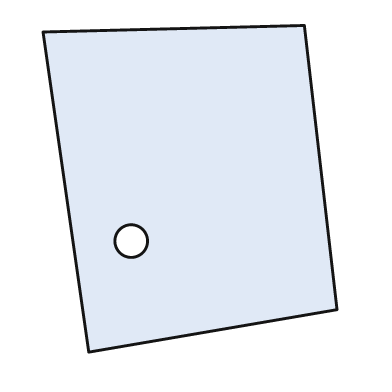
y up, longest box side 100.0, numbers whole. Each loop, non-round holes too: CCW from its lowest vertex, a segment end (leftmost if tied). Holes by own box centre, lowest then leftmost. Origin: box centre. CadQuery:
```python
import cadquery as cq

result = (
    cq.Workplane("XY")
    .moveTo(-31.0, -50.0)
    .lineTo(45.0, -37.0)
    .lineTo(35.0, 50.0)
    .lineTo(-45.0, 48.0)
    .close()
    .moveTo(-18.0, -16.0)
    .circle(5.0)
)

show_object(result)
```